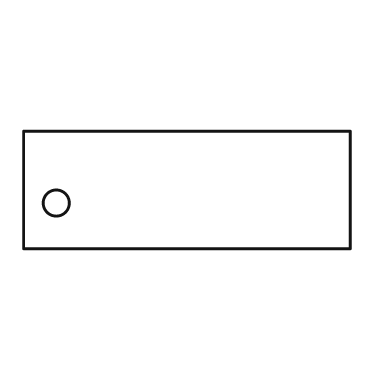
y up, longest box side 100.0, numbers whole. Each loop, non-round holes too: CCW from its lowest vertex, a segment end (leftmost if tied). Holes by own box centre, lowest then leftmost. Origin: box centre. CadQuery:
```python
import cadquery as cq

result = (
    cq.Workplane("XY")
    .moveTo(-50.0, -18.0)
    .lineTo(50.0, -18.0)
    .lineTo(50.0, 18.0)
    .lineTo(-50.0, 18.0)
    .close()
    .moveTo(-40.0, -4.0)
    .circle(4.0)
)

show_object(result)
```